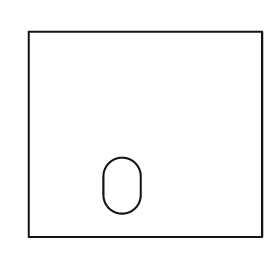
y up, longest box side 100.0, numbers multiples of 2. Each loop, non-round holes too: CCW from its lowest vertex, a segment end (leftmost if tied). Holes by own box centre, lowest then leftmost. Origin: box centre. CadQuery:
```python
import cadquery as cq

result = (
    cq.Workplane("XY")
    .moveTo(-50.0, -44.0)
    .lineTo(50.0, -44.0)
    .lineTo(50.0, 44.0)
    .lineTo(-50.0, 44.0)
    .close()
    .moveTo(-18.0, -26.0)
    .threePointArc((-10.0, -34.0), (-2.0, -26.0))
    .lineTo(-2.0, -18.0)
    .threePointArc((-10.0, -10.0), (-18.0, -18.0))
    .close()
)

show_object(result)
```